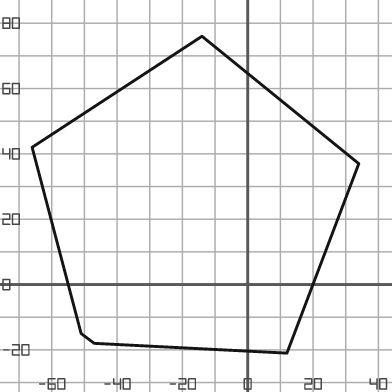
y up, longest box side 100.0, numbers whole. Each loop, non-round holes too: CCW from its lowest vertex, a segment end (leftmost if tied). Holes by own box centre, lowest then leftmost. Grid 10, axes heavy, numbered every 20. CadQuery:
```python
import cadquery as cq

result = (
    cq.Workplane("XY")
    .moveTo(12.0, -21.0)
    .lineTo(34.0, 37.0)
    .lineTo(-14.0, 76.0)
    .lineTo(-66.0, 42.0)
    .lineTo(-51.0, -15.0)
    .lineTo(-47.0, -18.0)
    .close()
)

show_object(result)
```